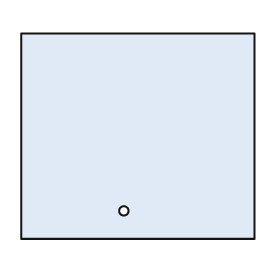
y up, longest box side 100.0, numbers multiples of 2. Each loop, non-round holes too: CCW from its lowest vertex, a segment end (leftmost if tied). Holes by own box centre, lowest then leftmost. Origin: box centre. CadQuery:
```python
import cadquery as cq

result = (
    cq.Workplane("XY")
    .moveTo(-50.0, -44.0)
    .lineTo(50.0, -44.0)
    .lineTo(50.0, 44.0)
    .lineTo(-50.0, 44.0)
    .close()
    .moveTo(-6.0, -32.0)
    .circle(2.0)
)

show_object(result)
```